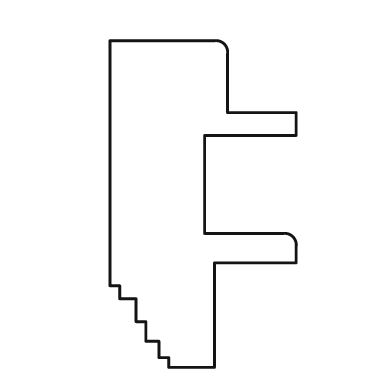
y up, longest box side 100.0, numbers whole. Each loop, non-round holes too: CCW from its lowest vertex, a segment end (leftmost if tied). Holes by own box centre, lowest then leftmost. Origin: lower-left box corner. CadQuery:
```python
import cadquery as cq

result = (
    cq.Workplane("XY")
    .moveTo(18.0, 0.0)
    .lineTo(32.0, 0.0)
    .lineTo(32.0, 32.0)
    .lineTo(57.0, 32.0)
    .lineTo(57.0, 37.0)
    .threePointArc((56.0, 40.0), (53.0, 41.0))
    .lineTo(29.0, 41.0)
    .lineTo(29.0, 71.0)
    .lineTo(57.0, 71.0)
    .lineTo(57.0, 78.0)
    .lineTo(36.0, 78.0)
    .lineTo(36.0, 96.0)
    .threePointArc((35.0, 99.0), (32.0, 100.0))
    .lineTo(0.0, 100.0)
    .lineTo(0.0, 25.0)
    .lineTo(3.0, 25.0)
    .lineTo(3.0, 21.0)
    .lineTo(8.0, 21.0)
    .lineTo(8.0, 14.0)
    .lineTo(11.0, 14.0)
    .lineTo(11.0, 8.0)
    .lineTo(15.0, 8.0)
    .lineTo(15.0, 3.0)
    .lineTo(18.0, 3.0)
    .close()
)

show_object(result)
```